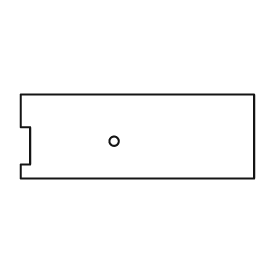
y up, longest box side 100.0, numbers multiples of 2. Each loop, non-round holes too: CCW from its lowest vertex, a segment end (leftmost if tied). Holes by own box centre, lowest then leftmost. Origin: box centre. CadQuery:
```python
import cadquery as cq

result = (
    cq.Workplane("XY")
    .moveTo(-50.0, -18.0)
    .lineTo(50.0, -18.0)
    .lineTo(50.0, 18.0)
    .lineTo(-50.0, 18.0)
    .lineTo(-50.0, 4.0)
    .lineTo(-46.0, 4.0)
    .lineTo(-46.0, -12.0)
    .lineTo(-50.0, -12.0)
    .close()
    .moveTo(-10.0, -2.0)
    .circle(2.0)
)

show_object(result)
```